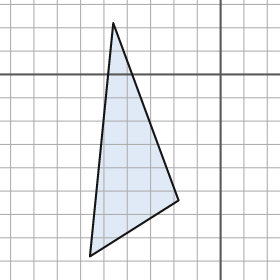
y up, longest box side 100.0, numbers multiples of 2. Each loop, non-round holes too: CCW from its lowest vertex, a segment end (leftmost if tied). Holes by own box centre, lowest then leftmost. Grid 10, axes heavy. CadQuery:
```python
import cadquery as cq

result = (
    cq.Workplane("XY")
    .moveTo(-56.0, -78.0)
    .lineTo(-18.0, -54.0)
    .lineTo(-46.0, 22.0)
    .close()
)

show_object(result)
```